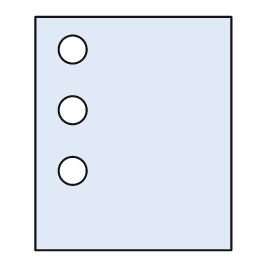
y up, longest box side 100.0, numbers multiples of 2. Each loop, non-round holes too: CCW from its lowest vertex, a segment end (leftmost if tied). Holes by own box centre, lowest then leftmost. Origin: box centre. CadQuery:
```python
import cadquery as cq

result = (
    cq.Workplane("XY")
    .moveTo(-42.0, -50.0)
    .lineTo(42.0, -50.0)
    .lineTo(42.0, 50.0)
    .lineTo(-42.0, 50.0)
    .close()
    .moveTo(-26.0, -16.0)
    .circle(6.0)
    .moveTo(-26.0, 10.0)
    .circle(6.0)
    .moveTo(-26.0, 36.0)
    .circle(6.0)
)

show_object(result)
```